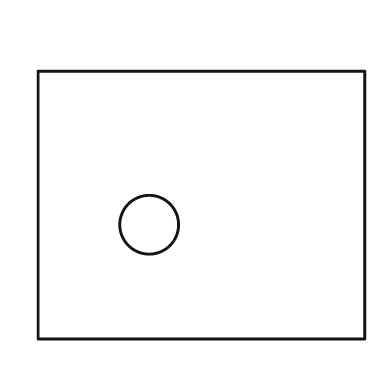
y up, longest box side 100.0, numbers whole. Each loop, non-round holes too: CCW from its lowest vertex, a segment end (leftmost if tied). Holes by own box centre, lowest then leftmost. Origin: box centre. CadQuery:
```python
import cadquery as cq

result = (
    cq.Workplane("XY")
    .moveTo(-50.0, -41.0)
    .lineTo(50.0, -41.0)
    .lineTo(50.0, 41.0)
    .lineTo(-50.0, 41.0)
    .close()
    .moveTo(-16.0, -6.0)
    .circle(9.0)
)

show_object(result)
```